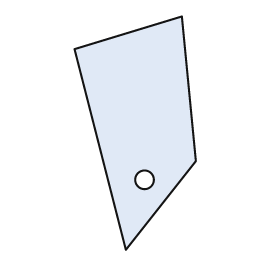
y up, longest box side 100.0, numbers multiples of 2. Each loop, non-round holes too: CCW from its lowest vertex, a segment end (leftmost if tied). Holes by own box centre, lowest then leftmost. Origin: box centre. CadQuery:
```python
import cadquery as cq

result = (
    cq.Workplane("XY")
    .moveTo(-4.0, -50.0)
    .lineTo(26.0, -12.0)
    .lineTo(20.0, 50.0)
    .lineTo(-26.0, 36.0)
    .close()
    .moveTo(4.0, -20.0)
    .circle(4.0)
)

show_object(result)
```